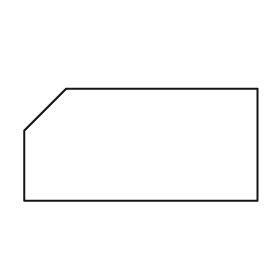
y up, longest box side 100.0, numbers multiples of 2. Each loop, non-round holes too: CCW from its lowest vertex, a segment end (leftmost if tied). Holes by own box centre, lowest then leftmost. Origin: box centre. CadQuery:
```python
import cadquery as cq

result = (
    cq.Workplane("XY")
    .moveTo(-50.0, -24.0)
    .lineTo(50.0, -24.0)
    .lineTo(50.0, 24.0)
    .lineTo(-32.0, 24.0)
    .lineTo(-50.0, 6.0)
    .close()
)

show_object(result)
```